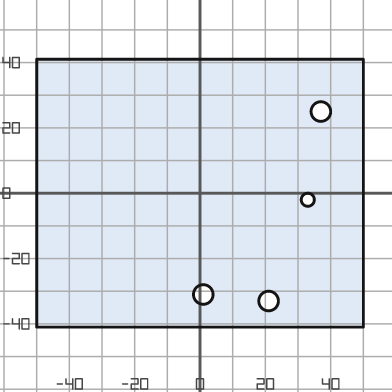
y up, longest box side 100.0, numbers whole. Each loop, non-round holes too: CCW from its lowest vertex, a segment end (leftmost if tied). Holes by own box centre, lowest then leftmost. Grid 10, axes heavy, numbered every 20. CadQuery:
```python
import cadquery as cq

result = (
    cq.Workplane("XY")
    .moveTo(-50.0, -41.0)
    .lineTo(50.0, -41.0)
    .lineTo(50.0, 41.0)
    .lineTo(-50.0, 41.0)
    .close()
    .moveTo(21.0, -33.0)
    .circle(3.0)
    .moveTo(1.0, -31.0)
    .circle(3.0)
    .moveTo(33.0, -2.0)
    .circle(2.0)
    .moveTo(37.0, 25.0)
    .circle(3.0)
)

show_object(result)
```